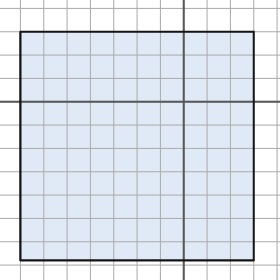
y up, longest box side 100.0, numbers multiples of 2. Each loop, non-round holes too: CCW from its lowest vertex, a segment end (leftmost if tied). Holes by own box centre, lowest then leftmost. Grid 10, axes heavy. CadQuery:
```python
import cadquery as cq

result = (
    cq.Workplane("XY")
    .moveTo(-70.0, -68.0)
    .lineTo(30.0, -68.0)
    .lineTo(30.0, 30.0)
    .lineTo(-70.0, 30.0)
    .close()
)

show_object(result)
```